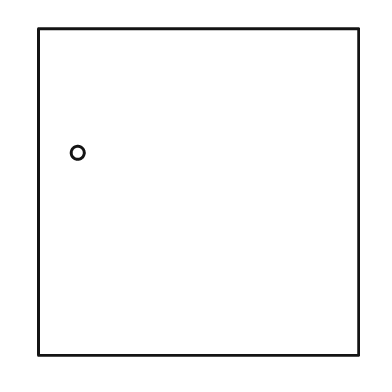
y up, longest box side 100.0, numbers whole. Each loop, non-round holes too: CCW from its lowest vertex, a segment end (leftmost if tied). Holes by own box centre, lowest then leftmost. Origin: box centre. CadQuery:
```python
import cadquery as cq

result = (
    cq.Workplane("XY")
    .moveTo(-49.0, -50.0)
    .lineTo(49.0, -50.0)
    .lineTo(49.0, 50.0)
    .lineTo(-49.0, 50.0)
    .close()
    .moveTo(-37.0, 12.0)
    .circle(2.0)
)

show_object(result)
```